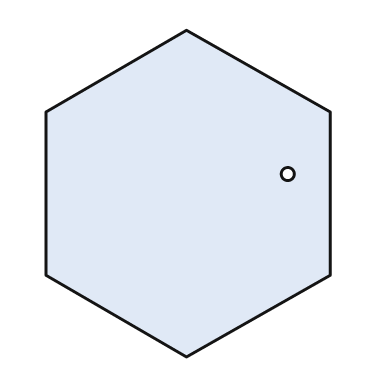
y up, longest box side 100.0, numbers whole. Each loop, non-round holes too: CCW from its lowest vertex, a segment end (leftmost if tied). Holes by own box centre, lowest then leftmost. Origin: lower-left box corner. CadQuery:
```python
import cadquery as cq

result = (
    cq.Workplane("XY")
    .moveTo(43.0, 0.0)
    .lineTo(87.0, 25.0)
    .lineTo(87.0, 75.0)
    .lineTo(43.0, 100.0)
    .lineTo(0.0, 75.0)
    .lineTo(0.0, 25.0)
    .close()
    .moveTo(74.0, 56.0)
    .circle(2.0)
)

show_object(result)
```